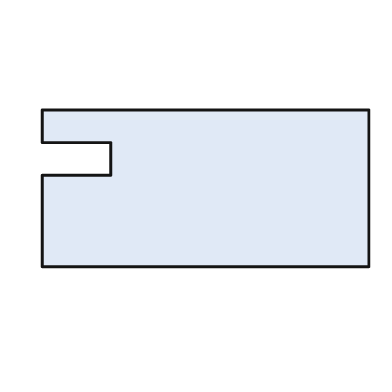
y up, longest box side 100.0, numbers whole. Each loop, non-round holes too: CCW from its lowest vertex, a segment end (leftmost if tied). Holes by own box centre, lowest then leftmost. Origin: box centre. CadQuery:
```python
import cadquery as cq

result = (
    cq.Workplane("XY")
    .moveTo(-50.0, -24.0)
    .lineTo(50.0, -24.0)
    .lineTo(50.0, 24.0)
    .lineTo(-50.0, 24.0)
    .lineTo(-50.0, 14.0)
    .lineTo(-29.0, 14.0)
    .lineTo(-29.0, 4.0)
    .lineTo(-50.0, 4.0)
    .close()
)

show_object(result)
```